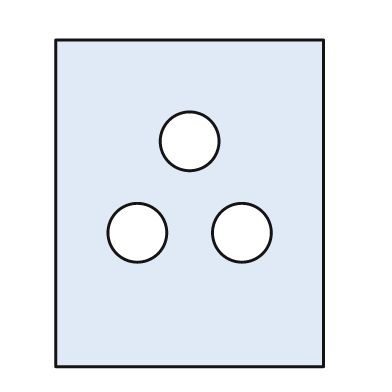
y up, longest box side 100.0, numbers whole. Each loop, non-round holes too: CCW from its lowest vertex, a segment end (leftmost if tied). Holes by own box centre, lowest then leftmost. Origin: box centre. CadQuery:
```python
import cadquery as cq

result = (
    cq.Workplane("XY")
    .moveTo(-41.0, -50.0)
    .lineTo(41.0, -50.0)
    .lineTo(41.0, 50.0)
    .lineTo(-41.0, 50.0)
    .close()
    .moveTo(-16.0, -9.0)
    .circle(9.0)
    .moveTo(16.0, -9.0)
    .circle(9.0)
    .moveTo(0.0, 19.0)
    .circle(9.0)
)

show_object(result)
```